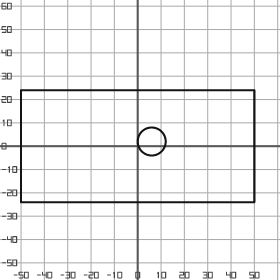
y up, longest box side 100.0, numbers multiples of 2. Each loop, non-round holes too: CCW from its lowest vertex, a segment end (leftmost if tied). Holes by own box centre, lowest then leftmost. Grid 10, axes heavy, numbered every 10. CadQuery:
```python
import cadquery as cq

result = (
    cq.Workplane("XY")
    .moveTo(-50.0, -24.0)
    .lineTo(50.0, -24.0)
    .lineTo(50.0, 24.0)
    .lineTo(-50.0, 24.0)
    .close()
    .moveTo(6.0, 2.0)
    .circle(6.0)
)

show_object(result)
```